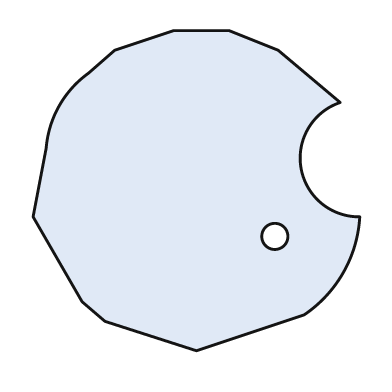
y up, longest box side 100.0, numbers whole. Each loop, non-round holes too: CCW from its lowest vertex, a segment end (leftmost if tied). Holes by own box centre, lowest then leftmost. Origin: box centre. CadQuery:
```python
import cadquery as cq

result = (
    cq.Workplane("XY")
    .moveTo(0.0, -49.0)
    .lineTo(33.0, -38.0)
    .threePointArc((45.0, -25.0), (50.0, -8.0))
    .threePointArc((32.0, 7.0), (44.0, 27.0))
    .lineTo(25.0, 43.0)
    .lineTo(10.0, 49.0)
    .lineTo(-7.0, 49.0)
    .lineTo(-25.0, 43.0)
    .lineTo(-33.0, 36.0)
    .threePointArc((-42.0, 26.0), (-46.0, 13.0))
    .lineTo(-50.0, -8.0)
    .lineTo(-35.0, -34.0)
    .lineTo(-28.0, -40.0)
    .close()
    .moveTo(24.0, -14.0)
    .circle(4.0)
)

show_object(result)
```